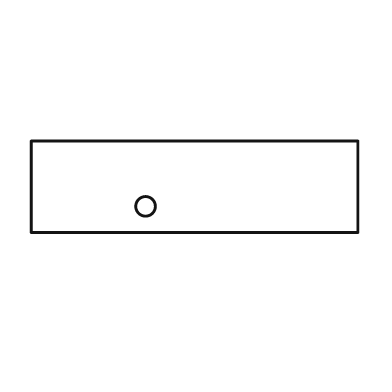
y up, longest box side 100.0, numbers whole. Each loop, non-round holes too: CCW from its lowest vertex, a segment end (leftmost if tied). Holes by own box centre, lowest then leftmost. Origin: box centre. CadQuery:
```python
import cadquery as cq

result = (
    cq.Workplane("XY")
    .moveTo(-50.0, -14.0)
    .lineTo(50.0, -14.0)
    .lineTo(50.0, 14.0)
    .lineTo(-50.0, 14.0)
    .close()
    .moveTo(-15.0, -6.0)
    .circle(3.0)
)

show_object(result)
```